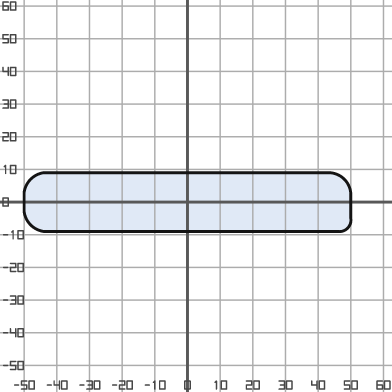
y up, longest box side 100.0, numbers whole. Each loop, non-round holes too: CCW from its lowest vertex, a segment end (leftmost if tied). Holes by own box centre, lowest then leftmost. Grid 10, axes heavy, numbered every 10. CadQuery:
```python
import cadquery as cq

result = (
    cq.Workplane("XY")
    .moveTo(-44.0, -9.0)
    .lineTo(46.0, -9.0)
    .threePointArc((49.0, -8.0), (50.0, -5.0))
    .lineTo(50.0, 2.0)
    .threePointArc((48.0, 7.0), (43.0, 9.0))
    .lineTo(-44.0, 9.0)
    .threePointArc((-48.0, 7.0), (-50.0, 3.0))
    .lineTo(-50.0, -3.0)
    .threePointArc((-48.0, -7.0), (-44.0, -9.0))
    .close()
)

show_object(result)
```